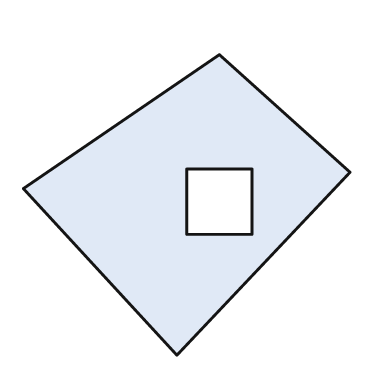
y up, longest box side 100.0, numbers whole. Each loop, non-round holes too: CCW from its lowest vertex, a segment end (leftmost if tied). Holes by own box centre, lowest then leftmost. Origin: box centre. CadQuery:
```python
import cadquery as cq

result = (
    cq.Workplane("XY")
    .moveTo(-3.0, -46.0)
    .lineTo(50.0, 10.0)
    .lineTo(10.0, 46.0)
    .lineTo(-50.0, 5.0)
    .close()
    .moveTo(0.0, -9.0)
    .lineTo(20.0, -9.0)
    .lineTo(20.0, 11.0)
    .lineTo(0.0, 11.0)
    .close()
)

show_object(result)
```